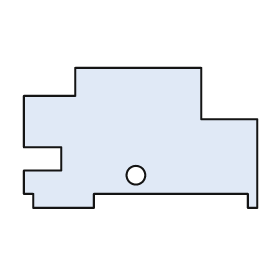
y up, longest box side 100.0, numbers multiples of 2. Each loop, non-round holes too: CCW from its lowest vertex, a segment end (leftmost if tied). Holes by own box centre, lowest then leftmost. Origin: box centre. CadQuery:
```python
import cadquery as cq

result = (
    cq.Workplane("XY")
    .moveTo(-46.0, -30.0)
    .lineTo(-20.0, -30.0)
    .lineTo(-20.0, -24.0)
    .lineTo(46.0, -24.0)
    .lineTo(46.0, -30.0)
    .lineTo(50.0, -30.0)
    .lineTo(50.0, 8.0)
    .lineTo(26.0, 8.0)
    .lineTo(26.0, 30.0)
    .lineTo(-28.0, 30.0)
    .lineTo(-28.0, 18.0)
    .lineTo(-50.0, 18.0)
    .lineTo(-50.0, -4.0)
    .lineTo(-34.0, -4.0)
    .lineTo(-34.0, -14.0)
    .lineTo(-50.0, -14.0)
    .lineTo(-50.0, -24.0)
    .lineTo(-46.0, -24.0)
    .close()
    .moveTo(-2.0, -16.0)
    .circle(4.0)
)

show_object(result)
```